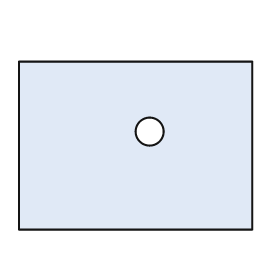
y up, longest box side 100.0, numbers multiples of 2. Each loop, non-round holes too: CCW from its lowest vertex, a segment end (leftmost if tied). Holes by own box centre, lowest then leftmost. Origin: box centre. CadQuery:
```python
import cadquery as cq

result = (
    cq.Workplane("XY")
    .moveTo(-50.0, -36.0)
    .lineTo(50.0, -36.0)
    .lineTo(50.0, 36.0)
    .lineTo(-50.0, 36.0)
    .close()
    .moveTo(6.0, 6.0)
    .circle(6.0)
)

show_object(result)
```